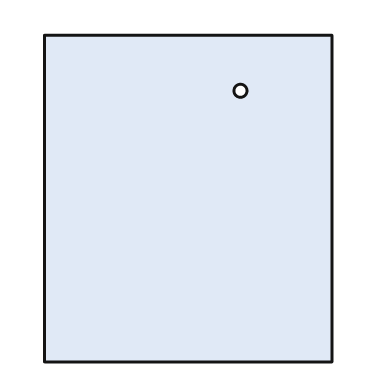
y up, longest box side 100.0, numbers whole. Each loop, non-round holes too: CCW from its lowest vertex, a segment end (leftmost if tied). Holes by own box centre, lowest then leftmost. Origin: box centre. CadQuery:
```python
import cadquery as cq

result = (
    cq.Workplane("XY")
    .moveTo(-44.0, -50.0)
    .lineTo(44.0, -50.0)
    .lineTo(44.0, 50.0)
    .lineTo(-44.0, 50.0)
    .close()
    .moveTo(16.0, 33.0)
    .circle(2.0)
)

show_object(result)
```